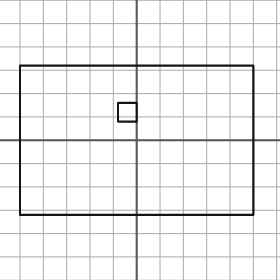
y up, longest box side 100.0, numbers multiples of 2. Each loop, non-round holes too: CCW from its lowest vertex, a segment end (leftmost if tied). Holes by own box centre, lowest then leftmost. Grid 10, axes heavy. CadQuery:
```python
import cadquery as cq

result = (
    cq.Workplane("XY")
    .moveTo(-50.0, -32.0)
    .lineTo(50.0, -32.0)
    .lineTo(50.0, 32.0)
    .lineTo(-50.0, 32.0)
    .close()
    .moveTo(-8.0, 8.0)
    .lineTo(0.0, 8.0)
    .lineTo(0.0, 16.0)
    .lineTo(-8.0, 16.0)
    .close()
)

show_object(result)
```